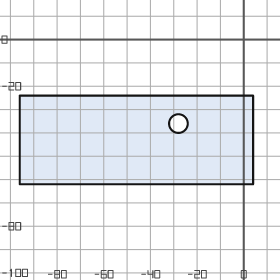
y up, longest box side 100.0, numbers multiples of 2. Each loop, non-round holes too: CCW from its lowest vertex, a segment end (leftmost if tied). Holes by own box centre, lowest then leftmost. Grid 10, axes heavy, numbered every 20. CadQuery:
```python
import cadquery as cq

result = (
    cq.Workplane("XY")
    .moveTo(-96.0, -62.0)
    .lineTo(4.0, -62.0)
    .lineTo(4.0, -24.0)
    .lineTo(-96.0, -24.0)
    .close()
    .moveTo(-28.0, -36.0)
    .circle(4.0)
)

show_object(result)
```